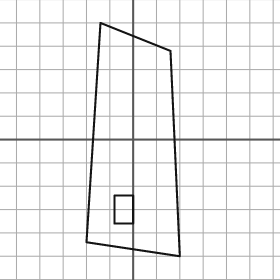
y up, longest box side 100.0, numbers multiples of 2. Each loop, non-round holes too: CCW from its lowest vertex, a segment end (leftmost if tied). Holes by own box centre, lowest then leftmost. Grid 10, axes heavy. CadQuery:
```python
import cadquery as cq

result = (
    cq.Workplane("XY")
    .moveTo(20.0, -50.0)
    .lineTo(16.0, 38.0)
    .lineTo(-14.0, 50.0)
    .lineTo(-20.0, -44.0)
    .close()
    .moveTo(-8.0, -36.0)
    .lineTo(0.0, -36.0)
    .lineTo(0.0, -24.0)
    .lineTo(-8.0, -24.0)
    .close()
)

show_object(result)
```